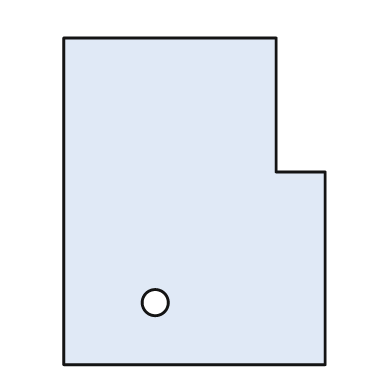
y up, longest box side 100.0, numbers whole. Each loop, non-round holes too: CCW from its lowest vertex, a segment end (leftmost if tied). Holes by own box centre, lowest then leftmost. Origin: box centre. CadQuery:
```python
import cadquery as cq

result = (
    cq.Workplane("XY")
    .moveTo(-40.0, -50.0)
    .lineTo(40.0, -50.0)
    .lineTo(40.0, 9.0)
    .lineTo(25.0, 9.0)
    .lineTo(25.0, 50.0)
    .lineTo(-40.0, 50.0)
    .close()
    .moveTo(-12.0, -31.0)
    .circle(4.0)
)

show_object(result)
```